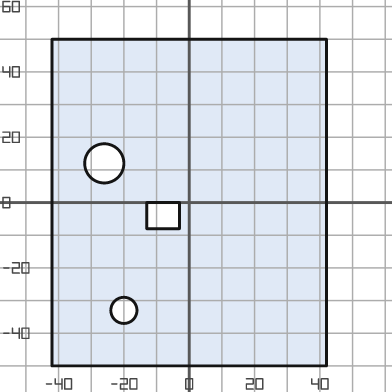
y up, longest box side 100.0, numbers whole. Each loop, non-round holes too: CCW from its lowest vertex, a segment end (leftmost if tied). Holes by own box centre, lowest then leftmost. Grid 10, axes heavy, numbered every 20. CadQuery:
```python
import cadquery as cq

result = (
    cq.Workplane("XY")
    .moveTo(-42.0, -50.0)
    .lineTo(42.0, -50.0)
    .lineTo(42.0, 50.0)
    .lineTo(-42.0, 50.0)
    .close()
    .moveTo(-20.0, -33.0)
    .circle(4.0)
    .moveTo(-13.0, -8.0)
    .lineTo(-3.0, -8.0)
    .lineTo(-3.0, 0.0)
    .lineTo(-13.0, 0.0)
    .close()
    .moveTo(-26.0, 12.0)
    .circle(6.0)
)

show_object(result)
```